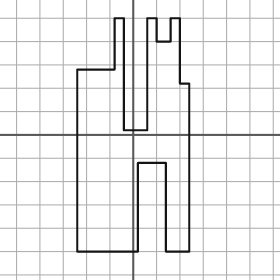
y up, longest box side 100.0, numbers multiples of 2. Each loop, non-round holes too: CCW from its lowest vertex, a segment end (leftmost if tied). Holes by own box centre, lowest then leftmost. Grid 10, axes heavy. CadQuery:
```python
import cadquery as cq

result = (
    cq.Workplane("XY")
    .moveTo(-24.0, -50.0)
    .lineTo(2.0, -50.0)
    .lineTo(2.0, -12.0)
    .lineTo(14.0, -12.0)
    .lineTo(14.0, -50.0)
    .lineTo(24.0, -50.0)
    .lineTo(24.0, 22.0)
    .lineTo(20.0, 22.0)
    .lineTo(20.0, 50.0)
    .lineTo(16.0, 50.0)
    .lineTo(16.0, 40.0)
    .lineTo(10.0, 40.0)
    .lineTo(10.0, 50.0)
    .lineTo(6.0, 50.0)
    .lineTo(6.0, 2.0)
    .lineTo(-4.0, 2.0)
    .lineTo(-4.0, 50.0)
    .lineTo(-8.0, 50.0)
    .lineTo(-8.0, 28.0)
    .lineTo(-24.0, 28.0)
    .close()
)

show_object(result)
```